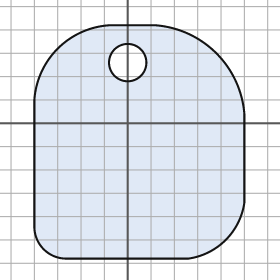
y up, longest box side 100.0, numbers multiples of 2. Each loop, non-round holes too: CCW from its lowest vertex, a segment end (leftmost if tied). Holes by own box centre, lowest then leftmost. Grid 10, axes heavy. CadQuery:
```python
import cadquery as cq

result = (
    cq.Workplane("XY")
    .moveTo(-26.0, -58.0)
    .lineTo(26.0, -58.0)
    .threePointArc((42.0, -50.0), (50.0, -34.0))
    .lineTo(50.0, 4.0)
    .threePointArc((38.0, 30.0), (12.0, 42.0))
    .lineTo(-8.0, 42.0)
    .threePointArc((-30.0, 32.0), (-40.0, 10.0))
    .lineTo(-40.0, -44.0)
    .threePointArc((-36.0, -54.0), (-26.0, -58.0))
    .close()
    .moveTo(0.0, 26.0)
    .circle(8.0)
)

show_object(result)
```